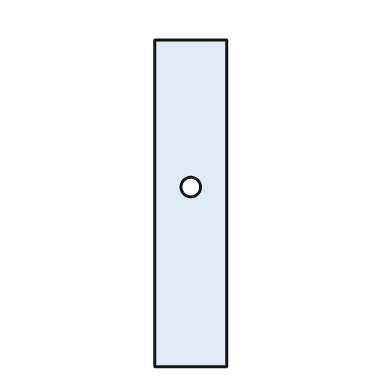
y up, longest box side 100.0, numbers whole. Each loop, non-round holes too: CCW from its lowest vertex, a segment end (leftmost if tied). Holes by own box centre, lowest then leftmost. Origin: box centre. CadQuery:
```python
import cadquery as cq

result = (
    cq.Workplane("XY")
    .moveTo(-11.0, -50.0)
    .lineTo(11.0, -50.0)
    .lineTo(11.0, 50.0)
    .lineTo(-11.0, 50.0)
    .close()
    .moveTo(0.0, 5.0)
    .circle(3.0)
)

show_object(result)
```